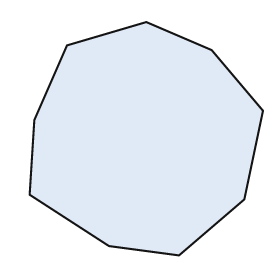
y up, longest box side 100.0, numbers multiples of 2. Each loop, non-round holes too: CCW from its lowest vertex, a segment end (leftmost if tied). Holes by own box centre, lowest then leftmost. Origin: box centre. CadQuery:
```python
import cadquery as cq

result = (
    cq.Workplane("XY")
    .moveTo(14.0, -50.0)
    .lineTo(42.0, -26.0)
    .lineTo(50.0, 12.0)
    .lineTo(28.0, 38.0)
    .lineTo(0.0, 50.0)
    .lineTo(-34.0, 40.0)
    .lineTo(-48.0, 8.0)
    .lineTo(-50.0, -24.0)
    .lineTo(-16.0, -46.0)
    .close()
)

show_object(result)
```